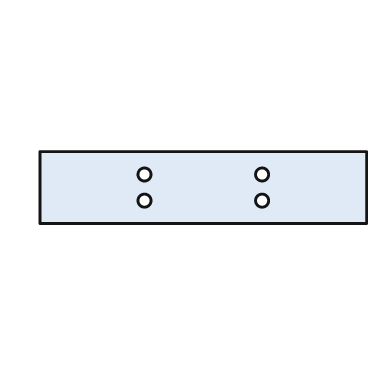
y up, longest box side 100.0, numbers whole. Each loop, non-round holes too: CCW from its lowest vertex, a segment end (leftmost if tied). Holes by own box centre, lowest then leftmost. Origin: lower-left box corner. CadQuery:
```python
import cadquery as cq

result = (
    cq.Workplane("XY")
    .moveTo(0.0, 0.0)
    .lineTo(100.0, 0.0)
    .lineTo(100.0, 22.0)
    .lineTo(0.0, 22.0)
    .close()
    .moveTo(32.0, 7.0)
    .circle(2.0)
    .moveTo(68.0, 7.0)
    .circle(2.0)
    .moveTo(32.0, 15.0)
    .circle(2.0)
    .moveTo(68.0, 15.0)
    .circle(2.0)
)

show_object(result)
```